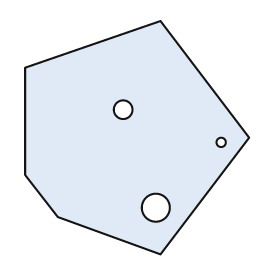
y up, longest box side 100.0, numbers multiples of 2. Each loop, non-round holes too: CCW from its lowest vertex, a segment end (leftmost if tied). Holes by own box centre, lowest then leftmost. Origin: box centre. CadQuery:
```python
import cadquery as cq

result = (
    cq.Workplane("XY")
    .moveTo(10.0, -50.0)
    .lineTo(48.0, 0.0)
    .lineTo(10.0, 50.0)
    .lineTo(-48.0, 30.0)
    .lineTo(-48.0, -16.0)
    .lineTo(-34.0, -34.0)
    .close()
    .moveTo(8.0, -30.0)
    .circle(6.0)
    .moveTo(36.0, -2.0)
    .circle(2.0)
    .moveTo(-6.0, 12.0)
    .circle(4.0)
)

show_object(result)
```